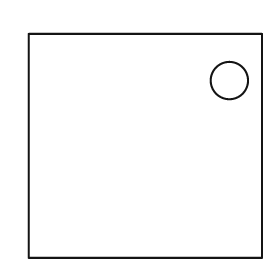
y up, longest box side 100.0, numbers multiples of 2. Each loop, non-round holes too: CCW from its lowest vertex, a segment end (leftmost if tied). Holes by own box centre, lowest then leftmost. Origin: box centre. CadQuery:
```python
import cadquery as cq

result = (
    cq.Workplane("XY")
    .moveTo(-50.0, -48.0)
    .lineTo(50.0, -48.0)
    .lineTo(50.0, 48.0)
    .lineTo(-50.0, 48.0)
    .close()
    .moveTo(36.0, 28.0)
    .circle(8.0)
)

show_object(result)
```